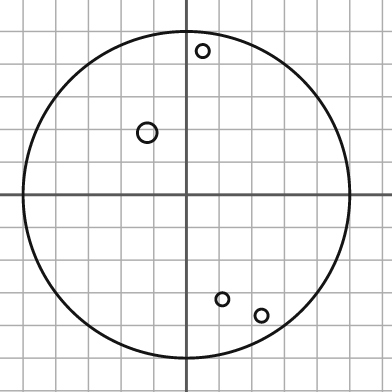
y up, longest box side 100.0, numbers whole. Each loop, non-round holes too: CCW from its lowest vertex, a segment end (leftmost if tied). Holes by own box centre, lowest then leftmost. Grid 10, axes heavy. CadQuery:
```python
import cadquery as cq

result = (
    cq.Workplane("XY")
    .moveTo(0.0, 0.0)
    .circle(50.0)
    .moveTo(23.0, -37.0)
    .circle(2.0)
    .moveTo(11.0, -32.0)
    .circle(2.0)
    .moveTo(-12.0, 19.0)
    .circle(3.0)
    .moveTo(5.0, 44.0)
    .circle(2.0)
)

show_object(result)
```